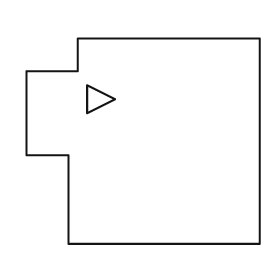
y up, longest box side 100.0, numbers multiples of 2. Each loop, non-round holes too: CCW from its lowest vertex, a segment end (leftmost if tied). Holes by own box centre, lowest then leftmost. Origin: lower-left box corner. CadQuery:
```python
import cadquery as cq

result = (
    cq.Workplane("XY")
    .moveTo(18.0, 0.0)
    .lineTo(100.0, 0.0)
    .lineTo(100.0, 88.0)
    .lineTo(22.0, 88.0)
    .lineTo(22.0, 74.0)
    .lineTo(0.0, 74.0)
    .lineTo(0.0, 38.0)
    .lineTo(18.0, 38.0)
    .close()
    .moveTo(26.0, 56.0)
    .lineTo(38.0, 62.0)
    .lineTo(26.0, 68.0)
    .close()
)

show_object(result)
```